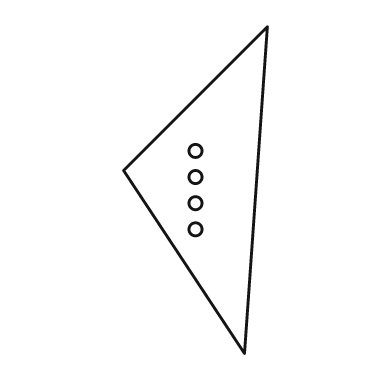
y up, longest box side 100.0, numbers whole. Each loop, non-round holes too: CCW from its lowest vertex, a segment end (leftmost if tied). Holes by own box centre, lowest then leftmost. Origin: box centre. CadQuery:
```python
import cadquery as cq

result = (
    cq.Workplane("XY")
    .moveTo(15.0, -50.0)
    .lineTo(22.0, 50.0)
    .lineTo(-22.0, 6.0)
    .close()
    .moveTo(0.0, -12.0)
    .circle(2.0)
    .moveTo(0.0, -4.0)
    .circle(2.0)
    .moveTo(0.0, 4.0)
    .circle(2.0)
    .moveTo(0.0, 12.0)
    .circle(2.0)
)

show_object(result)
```